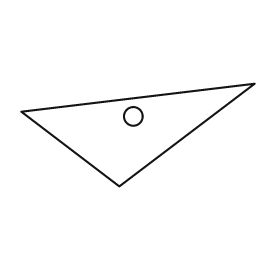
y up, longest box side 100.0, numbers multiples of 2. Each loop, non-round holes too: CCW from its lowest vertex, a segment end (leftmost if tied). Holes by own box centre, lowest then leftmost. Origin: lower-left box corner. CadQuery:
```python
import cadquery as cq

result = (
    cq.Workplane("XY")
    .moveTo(42.0, 0.0)
    .lineTo(100.0, 44.0)
    .lineTo(0.0, 32.0)
    .close()
    .moveTo(48.0, 30.0)
    .circle(4.0)
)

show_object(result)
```